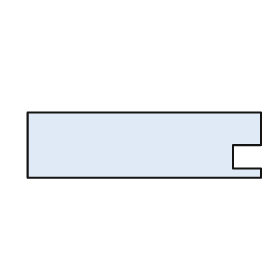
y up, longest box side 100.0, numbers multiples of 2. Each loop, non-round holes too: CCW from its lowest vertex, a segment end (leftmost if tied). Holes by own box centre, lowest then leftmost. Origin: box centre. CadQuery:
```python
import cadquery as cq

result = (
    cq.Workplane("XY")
    .moveTo(-50.0, -14.0)
    .lineTo(50.0, -14.0)
    .lineTo(50.0, -10.0)
    .lineTo(38.0, -10.0)
    .lineTo(38.0, 0.0)
    .lineTo(50.0, 0.0)
    .lineTo(50.0, 14.0)
    .lineTo(-50.0, 14.0)
    .close()
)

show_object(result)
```